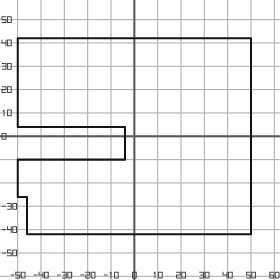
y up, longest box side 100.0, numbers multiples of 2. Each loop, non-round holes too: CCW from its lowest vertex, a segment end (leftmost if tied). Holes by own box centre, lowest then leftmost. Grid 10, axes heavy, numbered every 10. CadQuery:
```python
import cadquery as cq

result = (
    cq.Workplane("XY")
    .moveTo(-46.0, -42.0)
    .lineTo(50.0, -42.0)
    .lineTo(50.0, 42.0)
    .lineTo(-50.0, 42.0)
    .lineTo(-50.0, 4.0)
    .lineTo(-4.0, 4.0)
    .lineTo(-4.0, -10.0)
    .lineTo(-50.0, -10.0)
    .lineTo(-50.0, -26.0)
    .lineTo(-46.0, -26.0)
    .close()
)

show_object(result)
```